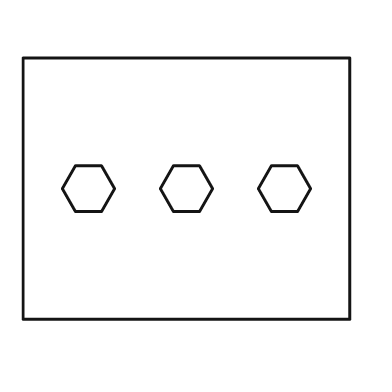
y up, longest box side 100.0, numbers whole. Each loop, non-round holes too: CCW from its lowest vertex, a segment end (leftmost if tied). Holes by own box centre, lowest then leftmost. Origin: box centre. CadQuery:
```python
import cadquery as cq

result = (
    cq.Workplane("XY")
    .moveTo(-50.0, -40.0)
    .lineTo(50.0, -40.0)
    .lineTo(50.0, 40.0)
    .lineTo(-50.0, 40.0)
    .close()
    .moveTo(-34.0, -7.0)
    .lineTo(-26.0, -7.0)
    .lineTo(-22.0, 0.0)
    .lineTo(-26.0, 7.0)
    .lineTo(-34.0, 7.0)
    .lineTo(-38.0, 0.0)
    .close()
    .moveTo(-4.0, -7.0)
    .lineTo(4.0, -7.0)
    .lineTo(8.0, 0.0)
    .lineTo(4.0, 7.0)
    .lineTo(-4.0, 7.0)
    .lineTo(-8.0, 0.0)
    .close()
    .moveTo(26.0, -7.0)
    .lineTo(34.0, -7.0)
    .lineTo(38.0, 0.0)
    .lineTo(34.0, 7.0)
    .lineTo(26.0, 7.0)
    .lineTo(22.0, 0.0)
    .close()
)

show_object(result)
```